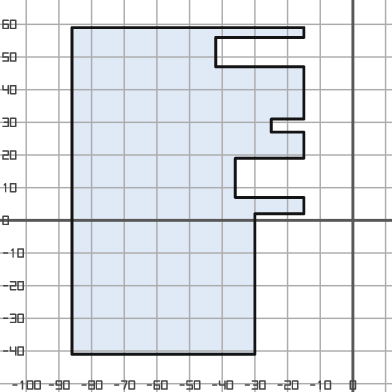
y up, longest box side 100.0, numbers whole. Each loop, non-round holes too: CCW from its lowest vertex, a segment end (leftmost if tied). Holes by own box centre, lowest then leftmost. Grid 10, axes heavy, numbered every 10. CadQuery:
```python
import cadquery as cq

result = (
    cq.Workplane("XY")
    .moveTo(-86.0, -41.0)
    .lineTo(-30.0, -41.0)
    .lineTo(-30.0, 2.0)
    .lineTo(-15.0, 2.0)
    .lineTo(-15.0, 7.0)
    .lineTo(-36.0, 7.0)
    .lineTo(-36.0, 19.0)
    .lineTo(-15.0, 19.0)
    .lineTo(-15.0, 27.0)
    .lineTo(-25.0, 27.0)
    .lineTo(-25.0, 31.0)
    .lineTo(-15.0, 31.0)
    .lineTo(-15.0, 47.0)
    .lineTo(-42.0, 47.0)
    .lineTo(-42.0, 56.0)
    .lineTo(-15.0, 56.0)
    .lineTo(-15.0, 59.0)
    .lineTo(-86.0, 59.0)
    .close()
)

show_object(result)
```